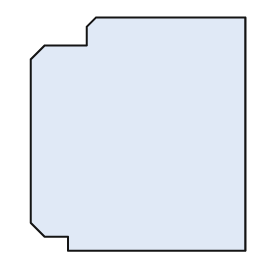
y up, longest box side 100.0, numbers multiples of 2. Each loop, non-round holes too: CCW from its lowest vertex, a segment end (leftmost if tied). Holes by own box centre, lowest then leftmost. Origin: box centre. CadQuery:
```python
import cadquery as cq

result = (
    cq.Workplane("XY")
    .moveTo(-30.0, -50.0)
    .lineTo(46.0, -50.0)
    .lineTo(46.0, 50.0)
    .lineTo(-18.0, 50.0)
    .lineTo(-22.0, 46.0)
    .lineTo(-22.0, 38.0)
    .lineTo(-40.0, 38.0)
    .lineTo(-46.0, 32.0)
    .lineTo(-46.0, -38.0)
    .lineTo(-40.0, -44.0)
    .lineTo(-30.0, -44.0)
    .close()
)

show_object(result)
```